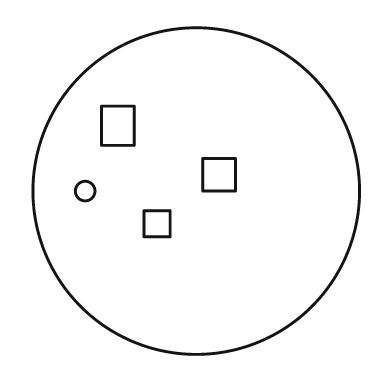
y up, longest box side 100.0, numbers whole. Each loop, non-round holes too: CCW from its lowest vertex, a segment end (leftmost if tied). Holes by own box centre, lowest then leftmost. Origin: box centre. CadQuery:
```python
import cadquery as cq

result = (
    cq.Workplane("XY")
    .moveTo(0.0, 0.0)
    .circle(50.0)
    .moveTo(-16.0, -14.0)
    .lineTo(-8.0, -14.0)
    .lineTo(-8.0, -6.0)
    .lineTo(-16.0, -6.0)
    .close()
    .moveTo(-34.0, 0.0)
    .circle(3.0)
    .moveTo(2.0, 0.0)
    .lineTo(12.0, 0.0)
    .lineTo(12.0, 10.0)
    .lineTo(2.0, 10.0)
    .close()
    .moveTo(-29.0, 14.0)
    .lineTo(-19.0, 14.0)
    .lineTo(-19.0, 26.0)
    .lineTo(-29.0, 26.0)
    .close()
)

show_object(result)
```